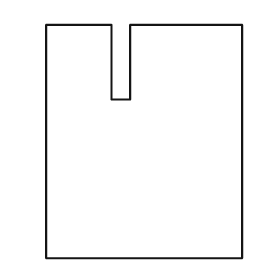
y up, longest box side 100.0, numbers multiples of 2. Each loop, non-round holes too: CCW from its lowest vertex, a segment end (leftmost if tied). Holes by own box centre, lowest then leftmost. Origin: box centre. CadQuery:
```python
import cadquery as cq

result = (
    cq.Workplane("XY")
    .moveTo(-42.0, -50.0)
    .lineTo(42.0, -50.0)
    .lineTo(42.0, 50.0)
    .lineTo(-6.0, 50.0)
    .lineTo(-6.0, 18.0)
    .lineTo(-14.0, 18.0)
    .lineTo(-14.0, 50.0)
    .lineTo(-42.0, 50.0)
    .close()
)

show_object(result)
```